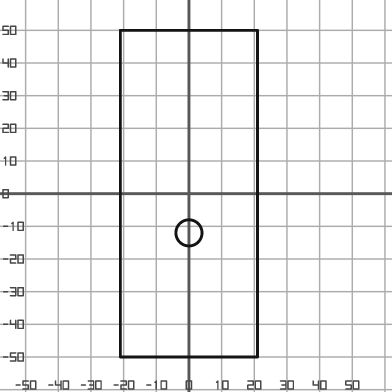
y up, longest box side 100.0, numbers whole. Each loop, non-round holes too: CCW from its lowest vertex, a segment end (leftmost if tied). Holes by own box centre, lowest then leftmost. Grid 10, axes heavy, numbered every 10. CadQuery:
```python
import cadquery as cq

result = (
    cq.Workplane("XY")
    .moveTo(-21.0, -50.0)
    .lineTo(21.0, -50.0)
    .lineTo(21.0, 50.0)
    .lineTo(-21.0, 50.0)
    .close()
    .moveTo(0.0, -12.0)
    .circle(4.0)
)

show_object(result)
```